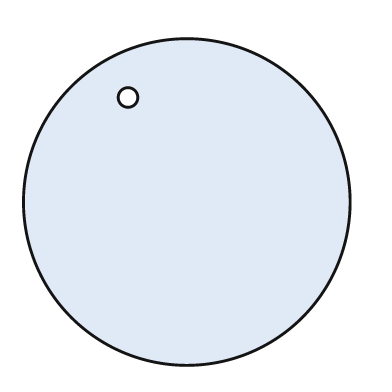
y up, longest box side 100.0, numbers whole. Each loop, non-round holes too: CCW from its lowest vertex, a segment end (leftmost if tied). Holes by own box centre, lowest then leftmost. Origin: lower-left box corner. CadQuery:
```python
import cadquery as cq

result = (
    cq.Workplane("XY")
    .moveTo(50.0, 50.0)
    .circle(50.0)
    .moveTo(32.0, 82.0)
    .circle(3.0)
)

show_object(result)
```